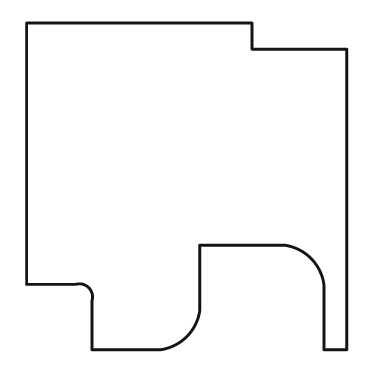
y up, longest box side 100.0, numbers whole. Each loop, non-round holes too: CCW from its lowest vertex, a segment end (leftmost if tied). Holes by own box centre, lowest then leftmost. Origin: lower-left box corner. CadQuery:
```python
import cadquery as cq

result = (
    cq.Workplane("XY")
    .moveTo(20.0, 0.0)
    .lineTo(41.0, 0.0)
    .threePointArc((49.0, 4.0), (53.0, 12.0))
    .lineTo(53.0, 32.0)
    .lineTo(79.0, 32.0)
    .threePointArc((87.0, 28.0), (91.0, 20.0))
    .lineTo(91.0, 0.0)
    .lineTo(98.0, 0.0)
    .lineTo(98.0, 92.0)
    .lineTo(69.0, 92.0)
    .lineTo(69.0, 100.0)
    .lineTo(0.0, 100.0)
    .lineTo(0.0, 20.0)
    .lineTo(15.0, 20.0)
    .threePointArc((19.0, 19.0), (20.0, 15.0))
    .close()
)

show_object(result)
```